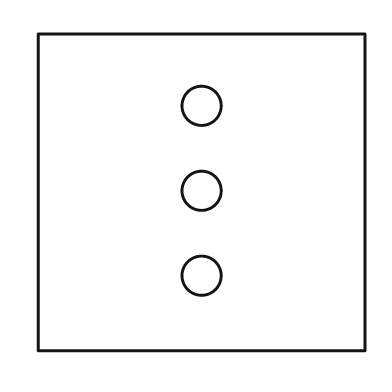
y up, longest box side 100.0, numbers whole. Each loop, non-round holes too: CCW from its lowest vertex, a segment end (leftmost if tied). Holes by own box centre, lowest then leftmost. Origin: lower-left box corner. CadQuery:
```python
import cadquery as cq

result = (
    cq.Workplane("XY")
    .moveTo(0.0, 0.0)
    .lineTo(100.0, 0.0)
    .lineTo(100.0, 97.0)
    .lineTo(0.0, 97.0)
    .close()
    .moveTo(50.0, 23.0)
    .circle(6.0)
    .moveTo(50.0, 49.0)
    .circle(6.0)
    .moveTo(50.0, 75.0)
    .circle(6.0)
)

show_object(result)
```